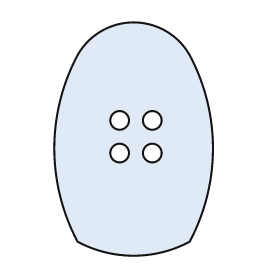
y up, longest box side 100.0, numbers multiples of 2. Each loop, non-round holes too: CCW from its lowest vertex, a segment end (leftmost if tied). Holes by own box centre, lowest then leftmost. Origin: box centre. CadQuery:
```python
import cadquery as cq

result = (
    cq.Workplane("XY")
    .moveTo(-24.0, -44.0)
    .threePointArc((0.0, -50.0), (24.0, -44.0))
    .threePointArc((34.0, -4.0), (24.0, 36.0))
    .threePointArc((0.0, 50.0), (-24.0, 36.0))
    .threePointArc((-34.0, -4.0), (-24.0, -44.0))
    .close()
    .moveTo(-6.0, -6.0)
    .circle(4.0)
    .moveTo(8.0, -6.0)
    .circle(4.0)
    .moveTo(-6.0, 8.0)
    .circle(4.0)
    .moveTo(8.0, 8.0)
    .circle(4.0)
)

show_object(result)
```